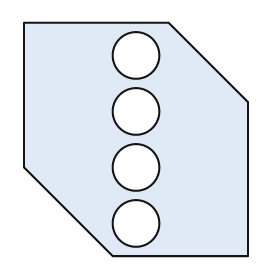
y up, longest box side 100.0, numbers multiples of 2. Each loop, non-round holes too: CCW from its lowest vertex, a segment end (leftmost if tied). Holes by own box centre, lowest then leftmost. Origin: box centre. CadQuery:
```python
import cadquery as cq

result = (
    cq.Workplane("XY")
    .moveTo(-10.0, -50.0)
    .lineTo(48.0, -50.0)
    .lineTo(48.0, 16.0)
    .lineTo(14.0, 50.0)
    .lineTo(-48.0, 50.0)
    .lineTo(-48.0, -12.0)
    .close()
    .moveTo(0.0, -36.0)
    .circle(10.0)
    .moveTo(0.0, -12.0)
    .circle(10.0)
    .moveTo(0.0, 12.0)
    .circle(10.0)
    .moveTo(0.0, 36.0)
    .circle(10.0)
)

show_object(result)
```